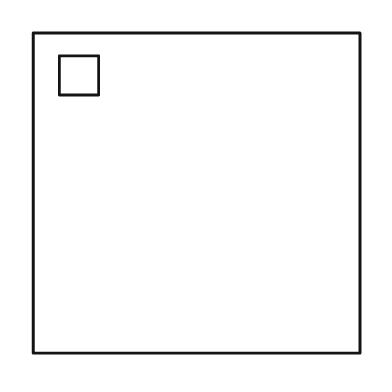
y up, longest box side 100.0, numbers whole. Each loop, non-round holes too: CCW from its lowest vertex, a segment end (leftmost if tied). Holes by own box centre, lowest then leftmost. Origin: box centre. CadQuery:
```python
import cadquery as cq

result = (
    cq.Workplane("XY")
    .moveTo(-50.0, -49.0)
    .lineTo(50.0, -49.0)
    .lineTo(50.0, 49.0)
    .lineTo(-50.0, 49.0)
    .close()
    .moveTo(-42.0, 30.0)
    .lineTo(-30.0, 30.0)
    .lineTo(-30.0, 42.0)
    .lineTo(-42.0, 42.0)
    .close()
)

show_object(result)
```